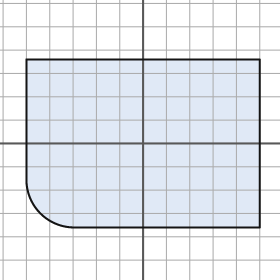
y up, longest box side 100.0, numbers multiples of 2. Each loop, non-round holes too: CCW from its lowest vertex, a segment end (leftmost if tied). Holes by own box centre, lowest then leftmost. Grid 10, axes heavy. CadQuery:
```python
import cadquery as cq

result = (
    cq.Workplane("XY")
    .moveTo(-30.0, -36.0)
    .lineTo(50.0, -36.0)
    .lineTo(50.0, 36.0)
    .lineTo(-50.0, 36.0)
    .lineTo(-50.0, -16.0)
    .threePointArc((-44.0, -30.0), (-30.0, -36.0))
    .close()
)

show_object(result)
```